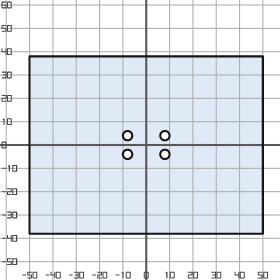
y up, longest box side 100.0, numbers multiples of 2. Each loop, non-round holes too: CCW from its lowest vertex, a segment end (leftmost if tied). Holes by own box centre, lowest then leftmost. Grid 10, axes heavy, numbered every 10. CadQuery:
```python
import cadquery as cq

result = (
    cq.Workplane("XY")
    .moveTo(-50.0, -38.0)
    .lineTo(50.0, -38.0)
    .lineTo(50.0, 38.0)
    .lineTo(-50.0, 38.0)
    .close()
    .moveTo(-8.0, -4.0)
    .circle(2.0)
    .moveTo(8.0, -4.0)
    .circle(2.0)
    .moveTo(-8.0, 4.0)
    .circle(2.0)
    .moveTo(8.0, 4.0)
    .circle(2.0)
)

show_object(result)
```